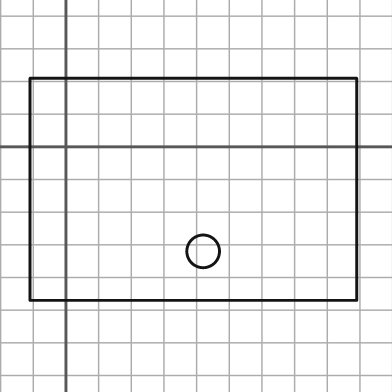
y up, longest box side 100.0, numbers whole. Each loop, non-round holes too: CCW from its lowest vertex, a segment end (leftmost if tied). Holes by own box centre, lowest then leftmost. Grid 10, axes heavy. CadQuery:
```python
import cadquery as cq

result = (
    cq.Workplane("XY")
    .moveTo(-11.0, -47.0)
    .lineTo(89.0, -47.0)
    .lineTo(89.0, 21.0)
    .lineTo(-11.0, 21.0)
    .close()
    .moveTo(42.0, -32.0)
    .circle(5.0)
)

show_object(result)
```